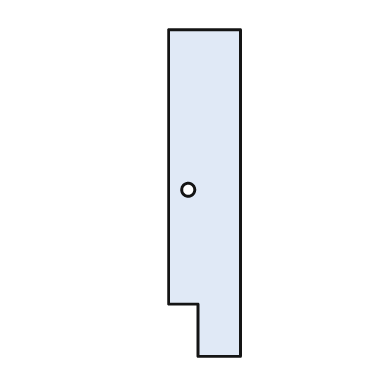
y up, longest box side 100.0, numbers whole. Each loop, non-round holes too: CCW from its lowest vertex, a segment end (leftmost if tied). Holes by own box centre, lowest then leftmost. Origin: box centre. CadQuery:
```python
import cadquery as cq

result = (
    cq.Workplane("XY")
    .moveTo(-2.0, -50.0)
    .lineTo(11.0, -50.0)
    .lineTo(11.0, 50.0)
    .lineTo(-11.0, 50.0)
    .lineTo(-11.0, -34.0)
    .lineTo(-2.0, -34.0)
    .close()
    .moveTo(-5.0, 1.0)
    .circle(2.0)
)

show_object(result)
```